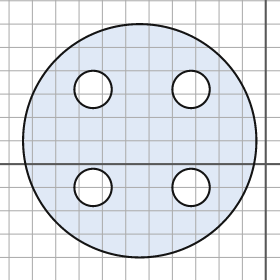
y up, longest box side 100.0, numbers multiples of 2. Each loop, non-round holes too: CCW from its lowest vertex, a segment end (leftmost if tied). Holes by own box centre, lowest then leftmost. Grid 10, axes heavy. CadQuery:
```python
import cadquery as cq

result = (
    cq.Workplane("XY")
    .moveTo(-54.0, 10.0)
    .circle(50.0)
    .moveTo(-74.0, -10.0)
    .circle(8.0)
    .moveTo(-32.0, -10.0)
    .circle(8.0)
    .moveTo(-74.0, 32.0)
    .circle(8.0)
    .moveTo(-32.0, 32.0)
    .circle(8.0)
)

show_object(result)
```